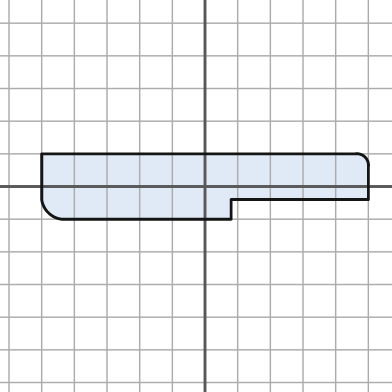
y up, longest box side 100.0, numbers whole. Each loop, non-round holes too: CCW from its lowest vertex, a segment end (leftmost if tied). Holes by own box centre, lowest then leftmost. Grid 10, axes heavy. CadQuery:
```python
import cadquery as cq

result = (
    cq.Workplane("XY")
    .moveTo(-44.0, -10.0)
    .lineTo(8.0, -10.0)
    .lineTo(8.0, -4.0)
    .lineTo(50.0, -4.0)
    .lineTo(50.0, 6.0)
    .threePointArc((49.0, 9.0), (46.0, 10.0))
    .lineTo(-50.0, 10.0)
    .lineTo(-50.0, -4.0)
    .threePointArc((-48.0, -8.0), (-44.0, -10.0))
    .close()
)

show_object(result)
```